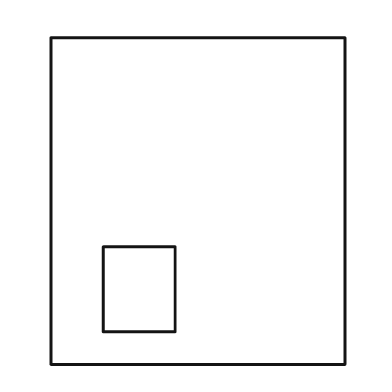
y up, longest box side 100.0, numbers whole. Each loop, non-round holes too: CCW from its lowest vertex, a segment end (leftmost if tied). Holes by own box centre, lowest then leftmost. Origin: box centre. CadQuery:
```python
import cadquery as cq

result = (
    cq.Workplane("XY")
    .moveTo(-45.0, -50.0)
    .lineTo(45.0, -50.0)
    .lineTo(45.0, 50.0)
    .lineTo(-45.0, 50.0)
    .close()
    .moveTo(-29.0, -40.0)
    .lineTo(-7.0, -40.0)
    .lineTo(-7.0, -14.0)
    .lineTo(-29.0, -14.0)
    .close()
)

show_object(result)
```